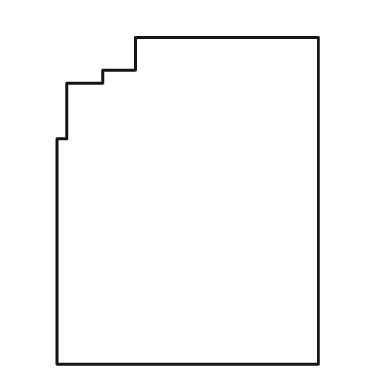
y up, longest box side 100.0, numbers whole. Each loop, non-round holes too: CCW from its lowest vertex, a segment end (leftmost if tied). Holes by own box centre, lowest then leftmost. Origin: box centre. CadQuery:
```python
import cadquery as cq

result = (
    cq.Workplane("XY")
    .moveTo(-40.0, -50.0)
    .lineTo(40.0, -50.0)
    .lineTo(40.0, 50.0)
    .lineTo(-16.0, 50.0)
    .lineTo(-16.0, 40.0)
    .lineTo(-26.0, 40.0)
    .lineTo(-26.0, 36.0)
    .lineTo(-37.0, 36.0)
    .lineTo(-37.0, 19.0)
    .lineTo(-40.0, 19.0)
    .close()
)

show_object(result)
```